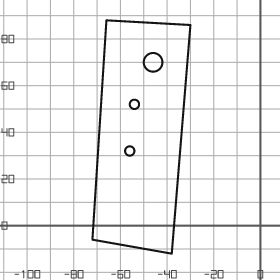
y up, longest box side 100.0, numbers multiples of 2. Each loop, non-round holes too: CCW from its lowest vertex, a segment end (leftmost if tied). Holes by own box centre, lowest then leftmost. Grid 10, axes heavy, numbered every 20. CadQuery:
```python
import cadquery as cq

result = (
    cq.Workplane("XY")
    .moveTo(-38.0, -12.0)
    .lineTo(-30.0, 86.0)
    .lineTo(-66.0, 88.0)
    .lineTo(-72.0, -6.0)
    .close()
    .moveTo(-56.0, 32.0)
    .circle(2.0)
    .moveTo(-54.0, 52.0)
    .circle(2.0)
    .moveTo(-46.0, 70.0)
    .circle(4.0)
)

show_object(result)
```